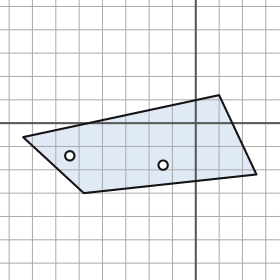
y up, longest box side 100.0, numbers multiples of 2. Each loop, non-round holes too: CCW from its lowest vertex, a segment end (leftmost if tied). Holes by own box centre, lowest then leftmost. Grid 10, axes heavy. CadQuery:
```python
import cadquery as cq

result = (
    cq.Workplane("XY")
    .moveTo(-48.0, -30.0)
    .lineTo(26.0, -22.0)
    .lineTo(10.0, 12.0)
    .lineTo(-74.0, -6.0)
    .close()
    .moveTo(-14.0, -18.0)
    .circle(2.0)
    .moveTo(-54.0, -14.0)
    .circle(2.0)
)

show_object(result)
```